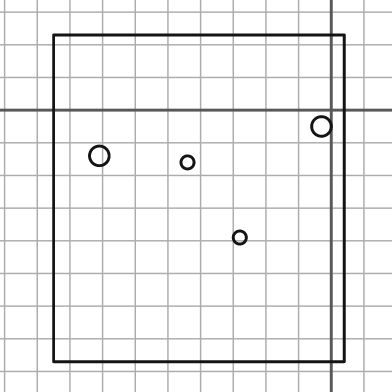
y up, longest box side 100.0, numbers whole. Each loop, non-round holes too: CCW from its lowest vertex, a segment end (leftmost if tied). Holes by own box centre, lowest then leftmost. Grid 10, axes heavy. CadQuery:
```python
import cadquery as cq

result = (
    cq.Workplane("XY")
    .moveTo(-85.0, -77.0)
    .lineTo(4.0, -77.0)
    .lineTo(4.0, 23.0)
    .lineTo(-85.0, 23.0)
    .close()
    .moveTo(-28.0, -39.0)
    .circle(2.0)
    .moveTo(-44.0, -16.0)
    .circle(2.0)
    .moveTo(-71.0, -14.0)
    .circle(3.0)
    .moveTo(-3.0, -5.0)
    .circle(3.0)
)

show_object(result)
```